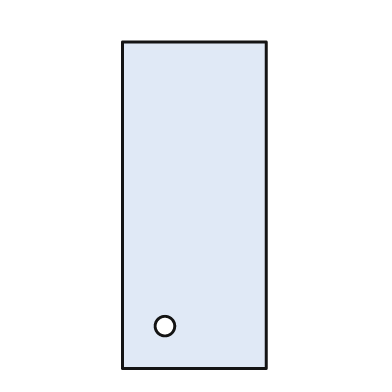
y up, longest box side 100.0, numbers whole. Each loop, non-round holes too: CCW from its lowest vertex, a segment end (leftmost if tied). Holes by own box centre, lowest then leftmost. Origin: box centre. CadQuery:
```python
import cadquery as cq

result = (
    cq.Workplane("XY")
    .moveTo(-22.0, -50.0)
    .lineTo(22.0, -50.0)
    .lineTo(22.0, 50.0)
    .lineTo(-22.0, 50.0)
    .close()
    .moveTo(-9.0, -37.0)
    .circle(3.0)
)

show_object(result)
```